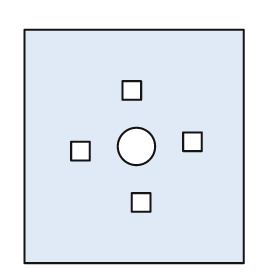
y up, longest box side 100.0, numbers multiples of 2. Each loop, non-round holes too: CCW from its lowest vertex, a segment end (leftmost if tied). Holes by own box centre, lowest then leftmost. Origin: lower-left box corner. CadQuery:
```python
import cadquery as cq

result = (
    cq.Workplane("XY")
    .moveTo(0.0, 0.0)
    .lineTo(94.0, 0.0)
    .lineTo(94.0, 100.0)
    .lineTo(0.0, 100.0)
    .close()
    .moveTo(46.0, 22.0)
    .lineTo(54.0, 22.0)
    .lineTo(54.0, 30.0)
    .lineTo(46.0, 30.0)
    .close()
    .moveTo(20.0, 44.0)
    .lineTo(28.0, 44.0)
    .lineTo(28.0, 52.0)
    .lineTo(20.0, 52.0)
    .close()
    .moveTo(48.0, 50.0)
    .circle(8.0)
    .moveTo(68.0, 48.0)
    .lineTo(76.0, 48.0)
    .lineTo(76.0, 56.0)
    .lineTo(68.0, 56.0)
    .close()
    .moveTo(42.0, 70.0)
    .lineTo(50.0, 70.0)
    .lineTo(50.0, 78.0)
    .lineTo(42.0, 78.0)
    .close()
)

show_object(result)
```